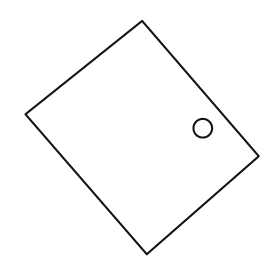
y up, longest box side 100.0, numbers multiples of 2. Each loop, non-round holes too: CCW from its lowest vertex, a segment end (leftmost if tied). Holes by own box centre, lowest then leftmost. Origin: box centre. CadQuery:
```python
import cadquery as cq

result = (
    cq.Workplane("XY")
    .moveTo(2.0, -50.0)
    .lineTo(50.0, -8.0)
    .lineTo(0.0, 50.0)
    .lineTo(-50.0, 10.0)
    .close()
    .moveTo(26.0, 4.0)
    .circle(4.0)
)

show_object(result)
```